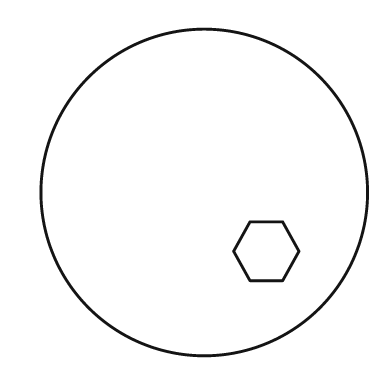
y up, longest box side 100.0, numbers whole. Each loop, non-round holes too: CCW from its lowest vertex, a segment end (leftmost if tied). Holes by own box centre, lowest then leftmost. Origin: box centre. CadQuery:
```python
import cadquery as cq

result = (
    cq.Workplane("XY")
    .moveTo(0.0, 0.0)
    .circle(50.0)
    .moveTo(14.0, -27.0)
    .lineTo(24.0, -27.0)
    .lineTo(29.0, -18.0)
    .lineTo(24.0, -9.0)
    .lineTo(14.0, -9.0)
    .lineTo(9.0, -18.0)
    .close()
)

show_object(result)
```